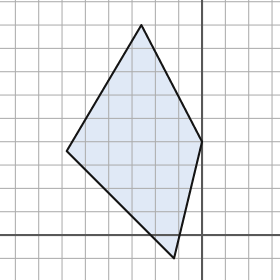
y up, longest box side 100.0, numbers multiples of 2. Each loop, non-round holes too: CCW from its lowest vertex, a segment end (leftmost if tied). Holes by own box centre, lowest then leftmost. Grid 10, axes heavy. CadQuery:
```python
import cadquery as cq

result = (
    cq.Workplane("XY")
    .moveTo(-12.0, -10.0)
    .lineTo(0.0, 40.0)
    .lineTo(-26.0, 90.0)
    .lineTo(-58.0, 36.0)
    .close()
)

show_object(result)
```